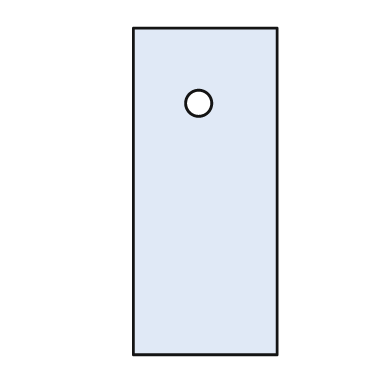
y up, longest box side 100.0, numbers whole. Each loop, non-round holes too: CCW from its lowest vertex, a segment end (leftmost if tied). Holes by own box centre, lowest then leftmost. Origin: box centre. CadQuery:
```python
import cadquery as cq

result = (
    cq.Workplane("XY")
    .moveTo(-22.0, -50.0)
    .lineTo(22.0, -50.0)
    .lineTo(22.0, 50.0)
    .lineTo(-22.0, 50.0)
    .close()
    .moveTo(-2.0, 27.0)
    .circle(4.0)
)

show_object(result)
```